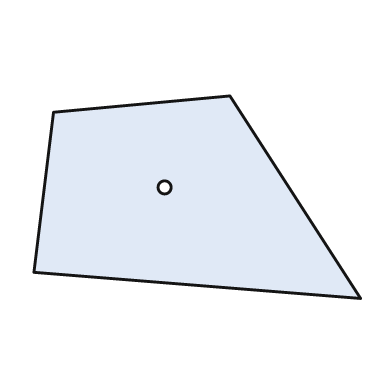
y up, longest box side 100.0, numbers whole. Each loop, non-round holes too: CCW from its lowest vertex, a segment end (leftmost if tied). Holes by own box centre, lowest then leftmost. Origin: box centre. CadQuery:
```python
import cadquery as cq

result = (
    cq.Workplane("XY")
    .moveTo(50.0, -31.0)
    .lineTo(10.0, 31.0)
    .lineTo(-44.0, 26.0)
    .lineTo(-50.0, -23.0)
    .close()
    .moveTo(-10.0, 3.0)
    .circle(2.0)
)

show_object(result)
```